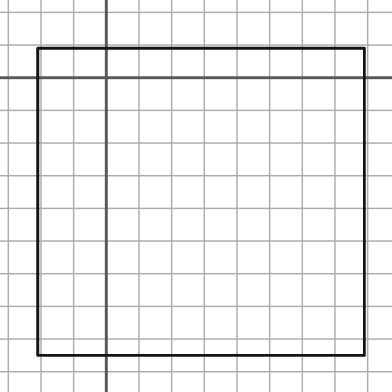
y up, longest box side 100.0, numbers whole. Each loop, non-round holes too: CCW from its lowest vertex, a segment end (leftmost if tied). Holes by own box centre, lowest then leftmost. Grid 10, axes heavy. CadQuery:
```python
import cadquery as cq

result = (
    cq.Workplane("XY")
    .moveTo(-21.0, -85.0)
    .lineTo(79.0, -85.0)
    .lineTo(79.0, 9.0)
    .lineTo(-21.0, 9.0)
    .close()
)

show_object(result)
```